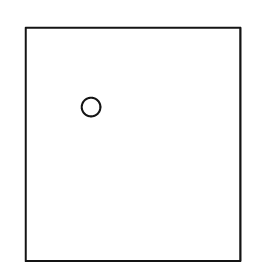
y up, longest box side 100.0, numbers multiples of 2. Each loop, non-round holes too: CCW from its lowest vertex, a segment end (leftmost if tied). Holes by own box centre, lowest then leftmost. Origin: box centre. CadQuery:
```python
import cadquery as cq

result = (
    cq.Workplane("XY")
    .moveTo(-46.0, -50.0)
    .lineTo(46.0, -50.0)
    .lineTo(46.0, 50.0)
    .lineTo(-46.0, 50.0)
    .close()
    .moveTo(-18.0, 16.0)
    .circle(4.0)
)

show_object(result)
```